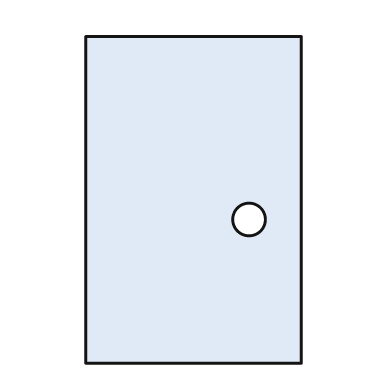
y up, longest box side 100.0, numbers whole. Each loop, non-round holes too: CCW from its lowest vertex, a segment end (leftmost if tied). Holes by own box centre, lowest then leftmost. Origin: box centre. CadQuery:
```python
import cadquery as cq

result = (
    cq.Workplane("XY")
    .moveTo(-33.0, -50.0)
    .lineTo(33.0, -50.0)
    .lineTo(33.0, 50.0)
    .lineTo(-33.0, 50.0)
    .close()
    .moveTo(17.0, -6.0)
    .circle(5.0)
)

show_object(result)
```